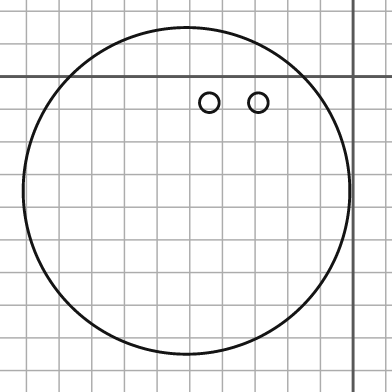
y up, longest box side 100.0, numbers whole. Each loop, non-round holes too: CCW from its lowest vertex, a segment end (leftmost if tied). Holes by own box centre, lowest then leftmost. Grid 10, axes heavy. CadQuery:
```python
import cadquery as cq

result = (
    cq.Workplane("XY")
    .moveTo(-51.0, -35.0)
    .circle(50.0)
    .moveTo(-44.0, -8.0)
    .circle(3.0)
    .moveTo(-29.0, -8.0)
    .circle(3.0)
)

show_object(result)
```